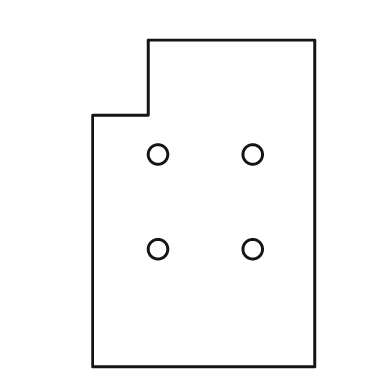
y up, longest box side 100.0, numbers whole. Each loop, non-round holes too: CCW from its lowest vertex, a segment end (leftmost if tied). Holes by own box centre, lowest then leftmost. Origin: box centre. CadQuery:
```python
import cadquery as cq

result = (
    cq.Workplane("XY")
    .moveTo(-34.0, -50.0)
    .lineTo(34.0, -50.0)
    .lineTo(34.0, 50.0)
    .lineTo(-17.0, 50.0)
    .lineTo(-17.0, 27.0)
    .lineTo(-34.0, 27.0)
    .close()
    .moveTo(-14.0, -14.0)
    .circle(3.0)
    .moveTo(15.0, -14.0)
    .circle(3.0)
    .moveTo(-14.0, 15.0)
    .circle(3.0)
    .moveTo(15.0, 15.0)
    .circle(3.0)
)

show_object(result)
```